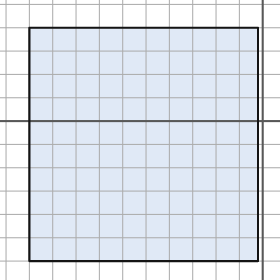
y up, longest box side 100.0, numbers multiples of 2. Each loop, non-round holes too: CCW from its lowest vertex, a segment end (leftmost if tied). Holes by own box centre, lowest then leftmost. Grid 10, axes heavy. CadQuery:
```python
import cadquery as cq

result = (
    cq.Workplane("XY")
    .moveTo(-100.0, -60.0)
    .lineTo(-2.0, -60.0)
    .lineTo(-2.0, 40.0)
    .lineTo(-100.0, 40.0)
    .close()
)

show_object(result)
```